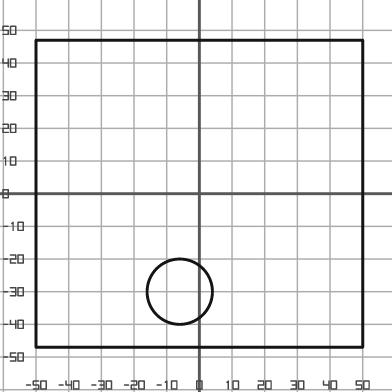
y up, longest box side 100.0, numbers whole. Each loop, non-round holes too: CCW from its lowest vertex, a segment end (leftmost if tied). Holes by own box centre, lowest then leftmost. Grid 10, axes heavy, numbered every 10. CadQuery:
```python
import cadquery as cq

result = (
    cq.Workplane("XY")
    .moveTo(-50.0, -47.0)
    .lineTo(50.0, -47.0)
    .lineTo(50.0, 47.0)
    .lineTo(-50.0, 47.0)
    .close()
    .moveTo(-6.0, -30.0)
    .circle(10.0)
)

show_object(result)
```